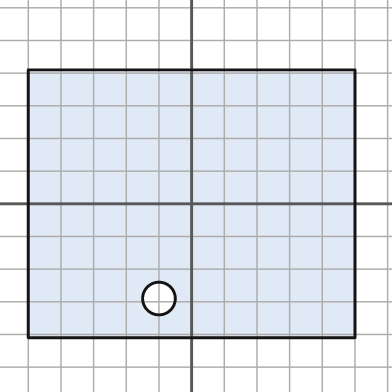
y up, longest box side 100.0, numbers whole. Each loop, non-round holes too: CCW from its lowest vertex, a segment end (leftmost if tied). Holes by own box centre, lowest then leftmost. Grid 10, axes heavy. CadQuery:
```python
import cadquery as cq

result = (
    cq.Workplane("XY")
    .moveTo(-50.0, -41.0)
    .lineTo(50.0, -41.0)
    .lineTo(50.0, 41.0)
    .lineTo(-50.0, 41.0)
    .close()
    .moveTo(-10.0, -29.0)
    .circle(5.0)
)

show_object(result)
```